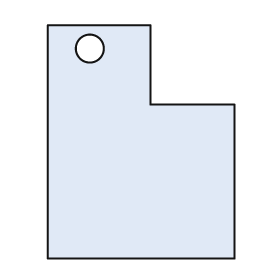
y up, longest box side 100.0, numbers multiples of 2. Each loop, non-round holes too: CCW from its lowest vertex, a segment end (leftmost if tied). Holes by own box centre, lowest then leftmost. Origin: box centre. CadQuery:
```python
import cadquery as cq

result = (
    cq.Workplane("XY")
    .moveTo(-40.0, -50.0)
    .lineTo(40.0, -50.0)
    .lineTo(40.0, 16.0)
    .lineTo(4.0, 16.0)
    .lineTo(4.0, 50.0)
    .lineTo(-40.0, 50.0)
    .close()
    .moveTo(-22.0, 40.0)
    .circle(6.0)
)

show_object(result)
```